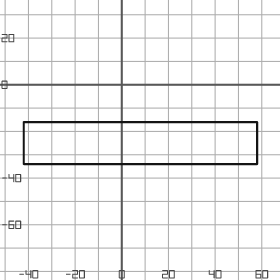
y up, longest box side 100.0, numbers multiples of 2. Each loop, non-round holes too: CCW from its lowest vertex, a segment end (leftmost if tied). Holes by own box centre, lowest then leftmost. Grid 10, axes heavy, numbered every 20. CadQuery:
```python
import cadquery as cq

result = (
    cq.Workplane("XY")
    .moveTo(-42.0, -34.0)
    .lineTo(58.0, -34.0)
    .lineTo(58.0, -16.0)
    .lineTo(-42.0, -16.0)
    .close()
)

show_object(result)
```